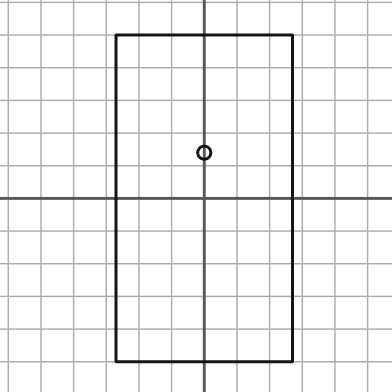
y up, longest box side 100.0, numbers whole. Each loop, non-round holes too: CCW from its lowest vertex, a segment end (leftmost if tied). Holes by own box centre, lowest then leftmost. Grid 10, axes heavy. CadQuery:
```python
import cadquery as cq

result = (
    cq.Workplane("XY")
    .moveTo(-27.0, -50.0)
    .lineTo(27.0, -50.0)
    .lineTo(27.0, 50.0)
    .lineTo(-27.0, 50.0)
    .close()
    .moveTo(0.0, 14.0)
    .circle(2.0)
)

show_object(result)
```